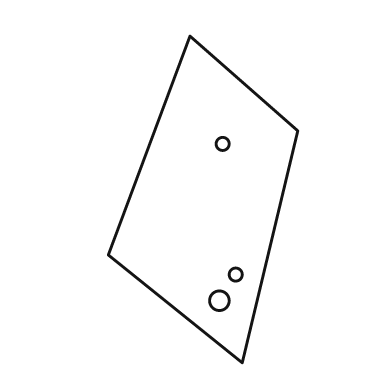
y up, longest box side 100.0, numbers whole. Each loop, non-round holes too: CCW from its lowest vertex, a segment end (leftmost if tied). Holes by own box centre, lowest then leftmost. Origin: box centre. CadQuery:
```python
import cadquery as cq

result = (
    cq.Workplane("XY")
    .moveTo(12.0, -50.0)
    .lineTo(29.0, 21.0)
    .lineTo(-4.0, 50.0)
    .lineTo(-29.0, -17.0)
    .close()
    .moveTo(5.0, -31.0)
    .circle(3.0)
    .moveTo(10.0, -23.0)
    .circle(2.0)
    .moveTo(6.0, 17.0)
    .circle(2.0)
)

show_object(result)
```